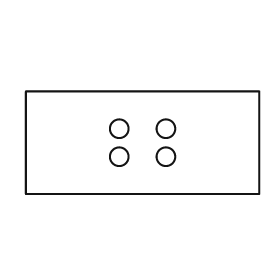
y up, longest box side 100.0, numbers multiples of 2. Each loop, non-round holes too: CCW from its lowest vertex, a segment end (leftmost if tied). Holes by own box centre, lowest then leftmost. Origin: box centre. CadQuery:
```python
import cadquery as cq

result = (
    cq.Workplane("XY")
    .moveTo(-50.0, -22.0)
    .lineTo(50.0, -22.0)
    .lineTo(50.0, 22.0)
    .lineTo(-50.0, 22.0)
    .close()
    .moveTo(-10.0, -6.0)
    .circle(4.0)
    .moveTo(10.0, -6.0)
    .circle(4.0)
    .moveTo(-10.0, 6.0)
    .circle(4.0)
    .moveTo(10.0, 6.0)
    .circle(4.0)
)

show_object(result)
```